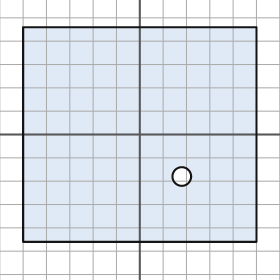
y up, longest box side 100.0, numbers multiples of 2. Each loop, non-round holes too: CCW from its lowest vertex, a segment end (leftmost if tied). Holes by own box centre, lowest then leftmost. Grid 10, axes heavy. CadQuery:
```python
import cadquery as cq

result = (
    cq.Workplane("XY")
    .moveTo(-50.0, -46.0)
    .lineTo(50.0, -46.0)
    .lineTo(50.0, 46.0)
    .lineTo(-50.0, 46.0)
    .close()
    .moveTo(18.0, -18.0)
    .circle(4.0)
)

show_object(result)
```